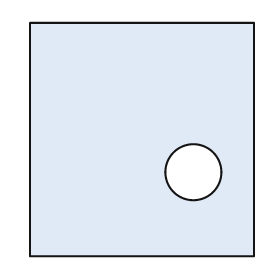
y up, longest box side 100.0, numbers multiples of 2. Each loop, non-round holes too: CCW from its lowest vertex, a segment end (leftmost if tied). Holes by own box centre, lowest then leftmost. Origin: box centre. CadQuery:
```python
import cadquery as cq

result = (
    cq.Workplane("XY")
    .moveTo(-48.0, -50.0)
    .lineTo(48.0, -50.0)
    .lineTo(48.0, 50.0)
    .lineTo(-48.0, 50.0)
    .close()
    .moveTo(22.0, -14.0)
    .circle(12.0)
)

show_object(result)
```